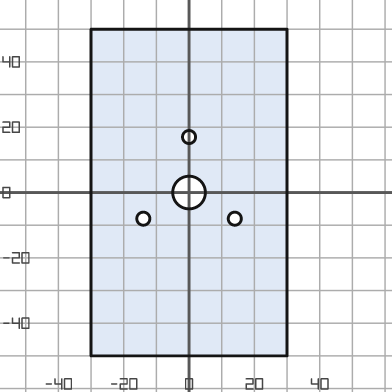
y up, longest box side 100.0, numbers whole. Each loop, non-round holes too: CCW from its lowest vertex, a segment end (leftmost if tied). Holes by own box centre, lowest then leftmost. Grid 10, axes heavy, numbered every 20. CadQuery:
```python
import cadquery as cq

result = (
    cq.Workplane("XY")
    .moveTo(-30.0, -50.0)
    .lineTo(30.0, -50.0)
    .lineTo(30.0, 50.0)
    .lineTo(-30.0, 50.0)
    .close()
    .moveTo(-14.0, -8.0)
    .circle(2.0)
    .moveTo(14.0, -8.0)
    .circle(2.0)
    .moveTo(0.0, 0.0)
    .circle(5.0)
    .moveTo(0.0, 17.0)
    .circle(2.0)
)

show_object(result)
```